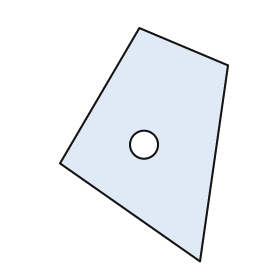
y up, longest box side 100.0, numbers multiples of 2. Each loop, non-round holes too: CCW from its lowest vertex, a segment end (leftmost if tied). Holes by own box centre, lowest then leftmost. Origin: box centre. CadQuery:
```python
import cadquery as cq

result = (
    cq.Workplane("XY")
    .moveTo(24.0, -50.0)
    .lineTo(36.0, 34.0)
    .lineTo(-2.0, 50.0)
    .lineTo(-36.0, -8.0)
    .close()
    .moveTo(0.0, 0.0)
    .circle(6.0)
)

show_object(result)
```